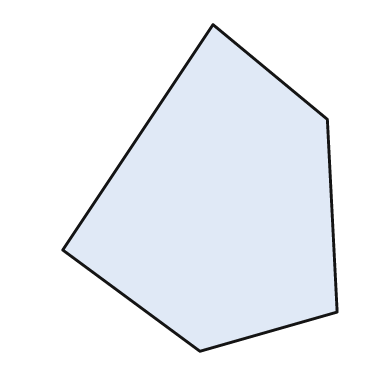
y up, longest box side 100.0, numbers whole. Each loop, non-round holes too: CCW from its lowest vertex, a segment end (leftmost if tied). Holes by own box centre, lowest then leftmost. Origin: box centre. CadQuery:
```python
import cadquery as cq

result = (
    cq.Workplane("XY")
    .moveTo(0.0, -50.0)
    .lineTo(42.0, -38.0)
    .lineTo(39.0, 21.0)
    .lineTo(4.0, 50.0)
    .lineTo(-42.0, -19.0)
    .close()
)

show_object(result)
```